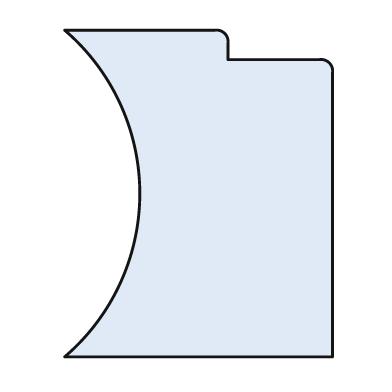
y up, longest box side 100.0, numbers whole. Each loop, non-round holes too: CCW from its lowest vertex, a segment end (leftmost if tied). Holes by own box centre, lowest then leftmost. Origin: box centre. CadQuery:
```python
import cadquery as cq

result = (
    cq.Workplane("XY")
    .moveTo(-41.0, -50.0)
    .lineTo(41.0, -50.0)
    .lineTo(41.0, 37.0)
    .threePointArc((40.0, 40.0), (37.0, 41.0))
    .lineTo(9.0, 41.0)
    .lineTo(9.0, 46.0)
    .threePointArc((8.0, 49.0), (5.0, 50.0))
    .lineTo(-41.0, 50.0)
    .threePointArc((-18.0, 0.0), (-41.0, -50.0))
    .close()
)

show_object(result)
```